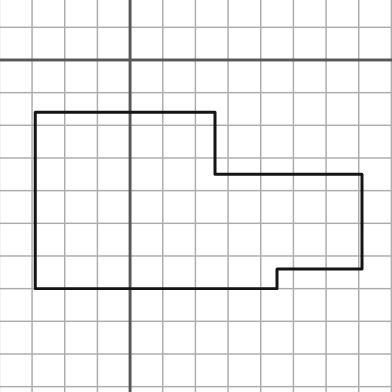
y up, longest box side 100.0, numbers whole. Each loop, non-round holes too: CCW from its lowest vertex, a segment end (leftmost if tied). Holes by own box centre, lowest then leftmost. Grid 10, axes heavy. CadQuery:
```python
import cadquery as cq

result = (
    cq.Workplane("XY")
    .moveTo(-29.0, -70.0)
    .lineTo(45.0, -70.0)
    .lineTo(45.0, -64.0)
    .lineTo(71.0, -64.0)
    .lineTo(71.0, -35.0)
    .lineTo(26.0, -35.0)
    .lineTo(26.0, -16.0)
    .lineTo(-29.0, -16.0)
    .close()
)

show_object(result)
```